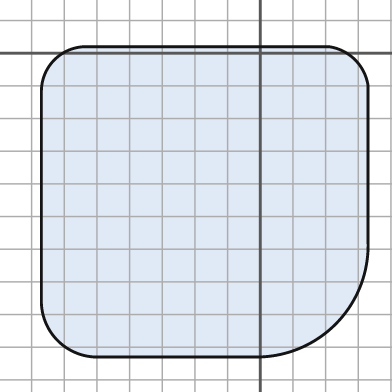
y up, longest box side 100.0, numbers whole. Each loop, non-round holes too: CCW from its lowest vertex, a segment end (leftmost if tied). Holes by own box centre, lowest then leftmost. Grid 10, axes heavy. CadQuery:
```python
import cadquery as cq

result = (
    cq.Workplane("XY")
    .moveTo(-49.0, -93.0)
    .lineTo(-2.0, -93.0)
    .threePointArc((23.0, -83.0), (33.0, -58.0))
    .lineTo(33.0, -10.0)
    .threePointArc((29.0, -2.0), (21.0, 2.0))
    .lineTo(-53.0, 2.0)
    .threePointArc((-63.0, -2.0), (-67.0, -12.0))
    .lineTo(-67.0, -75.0)
    .threePointArc((-62.0, -88.0), (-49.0, -93.0))
    .close()
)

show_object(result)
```